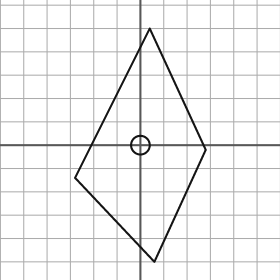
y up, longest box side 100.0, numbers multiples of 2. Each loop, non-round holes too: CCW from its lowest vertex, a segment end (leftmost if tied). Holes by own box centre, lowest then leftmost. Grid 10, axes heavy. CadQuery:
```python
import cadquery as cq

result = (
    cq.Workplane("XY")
    .moveTo(6.0, -50.0)
    .lineTo(28.0, -2.0)
    .lineTo(4.0, 50.0)
    .lineTo(-28.0, -14.0)
    .close()
    .moveTo(0.0, 0.0)
    .circle(4.0)
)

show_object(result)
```